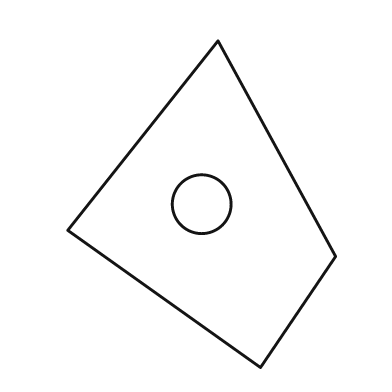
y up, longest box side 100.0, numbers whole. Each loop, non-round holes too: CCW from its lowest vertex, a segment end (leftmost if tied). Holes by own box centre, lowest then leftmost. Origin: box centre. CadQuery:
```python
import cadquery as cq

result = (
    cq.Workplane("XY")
    .moveTo(18.0, -50.0)
    .lineTo(41.0, -16.0)
    .lineTo(5.0, 50.0)
    .lineTo(-41.0, -8.0)
    .close()
    .moveTo(0.0, 0.0)
    .circle(9.0)
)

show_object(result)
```